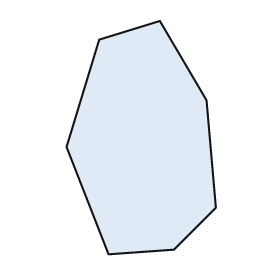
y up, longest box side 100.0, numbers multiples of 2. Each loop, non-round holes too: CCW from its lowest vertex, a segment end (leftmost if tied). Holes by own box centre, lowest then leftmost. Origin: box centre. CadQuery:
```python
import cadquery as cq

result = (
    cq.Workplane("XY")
    .moveTo(-14.0, -50.0)
    .lineTo(14.0, -48.0)
    .lineTo(32.0, -30.0)
    .lineTo(28.0, 16.0)
    .lineTo(8.0, 50.0)
    .lineTo(-18.0, 42.0)
    .lineTo(-32.0, -4.0)
    .close()
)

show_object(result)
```